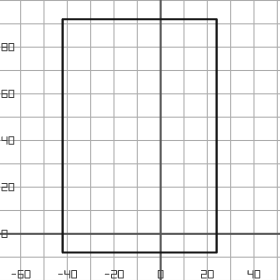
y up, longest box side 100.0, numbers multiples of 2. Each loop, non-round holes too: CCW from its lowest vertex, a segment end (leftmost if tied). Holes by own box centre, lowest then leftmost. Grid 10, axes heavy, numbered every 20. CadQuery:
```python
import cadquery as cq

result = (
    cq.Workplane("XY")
    .moveTo(-42.0, -8.0)
    .lineTo(24.0, -8.0)
    .lineTo(24.0, 92.0)
    .lineTo(-42.0, 92.0)
    .close()
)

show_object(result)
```